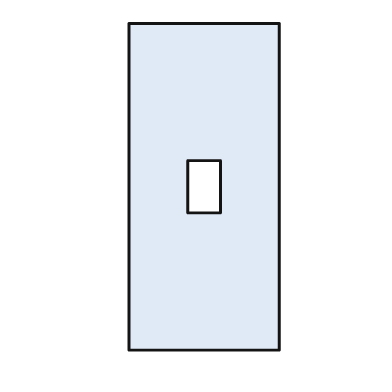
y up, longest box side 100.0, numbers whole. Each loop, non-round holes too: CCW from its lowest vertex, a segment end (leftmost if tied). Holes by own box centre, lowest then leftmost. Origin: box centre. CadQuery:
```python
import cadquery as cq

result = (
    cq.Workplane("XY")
    .moveTo(-23.0, -50.0)
    .lineTo(23.0, -50.0)
    .lineTo(23.0, 50.0)
    .lineTo(-23.0, 50.0)
    .close()
    .moveTo(-5.0, -8.0)
    .lineTo(5.0, -8.0)
    .lineTo(5.0, 8.0)
    .lineTo(-5.0, 8.0)
    .close()
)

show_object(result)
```